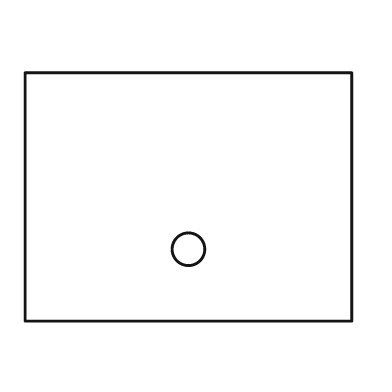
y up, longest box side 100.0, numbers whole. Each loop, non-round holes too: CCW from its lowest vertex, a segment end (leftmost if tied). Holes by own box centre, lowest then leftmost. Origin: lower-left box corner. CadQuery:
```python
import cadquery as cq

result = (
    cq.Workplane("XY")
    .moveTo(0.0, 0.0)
    .lineTo(100.0, 0.0)
    .lineTo(100.0, 76.0)
    .lineTo(0.0, 76.0)
    .close()
    .moveTo(50.0, 22.0)
    .circle(5.0)
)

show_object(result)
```